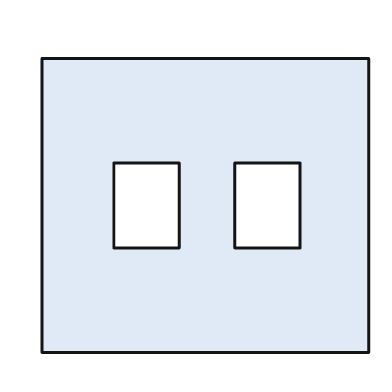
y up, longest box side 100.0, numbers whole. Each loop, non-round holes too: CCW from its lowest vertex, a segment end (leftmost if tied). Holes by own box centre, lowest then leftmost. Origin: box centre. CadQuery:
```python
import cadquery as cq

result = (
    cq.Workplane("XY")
    .moveTo(-50.0, -45.0)
    .lineTo(50.0, -45.0)
    .lineTo(50.0, 45.0)
    .lineTo(-50.0, 45.0)
    .close()
    .moveTo(-28.0, -13.0)
    .lineTo(-8.0, -13.0)
    .lineTo(-8.0, 13.0)
    .lineTo(-28.0, 13.0)
    .close()
    .moveTo(9.0, -13.0)
    .lineTo(29.0, -13.0)
    .lineTo(29.0, 13.0)
    .lineTo(9.0, 13.0)
    .close()
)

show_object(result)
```